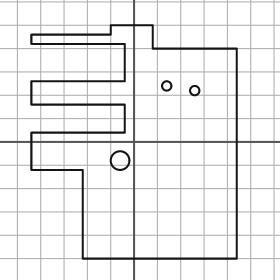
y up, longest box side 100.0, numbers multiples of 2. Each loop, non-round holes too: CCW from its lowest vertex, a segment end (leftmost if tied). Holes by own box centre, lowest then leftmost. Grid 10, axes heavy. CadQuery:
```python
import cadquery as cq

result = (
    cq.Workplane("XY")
    .moveTo(-22.0, -50.0)
    .lineTo(44.0, -50.0)
    .lineTo(44.0, 40.0)
    .lineTo(8.0, 40.0)
    .lineTo(8.0, 50.0)
    .lineTo(-10.0, 50.0)
    .lineTo(-10.0, 46.0)
    .lineTo(-44.0, 46.0)
    .lineTo(-44.0, 42.0)
    .lineTo(-4.0, 42.0)
    .lineTo(-4.0, 26.0)
    .lineTo(-44.0, 26.0)
    .lineTo(-44.0, 16.0)
    .lineTo(-4.0, 16.0)
    .lineTo(-4.0, 4.0)
    .lineTo(-44.0, 4.0)
    .lineTo(-44.0, -12.0)
    .lineTo(-22.0, -12.0)
    .close()
    .moveTo(-6.0, -8.0)
    .circle(4.0)
    .moveTo(26.0, 22.0)
    .circle(2.0)
    .moveTo(14.0, 24.0)
    .circle(2.0)
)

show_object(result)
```